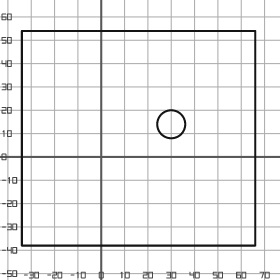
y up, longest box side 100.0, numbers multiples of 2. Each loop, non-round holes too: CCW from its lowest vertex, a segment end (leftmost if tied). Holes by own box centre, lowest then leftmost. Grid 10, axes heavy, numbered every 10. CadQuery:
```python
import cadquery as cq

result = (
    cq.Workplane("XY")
    .moveTo(-34.0, -38.0)
    .lineTo(66.0, -38.0)
    .lineTo(66.0, 54.0)
    .lineTo(-34.0, 54.0)
    .close()
    .moveTo(30.0, 14.0)
    .circle(6.0)
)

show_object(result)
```